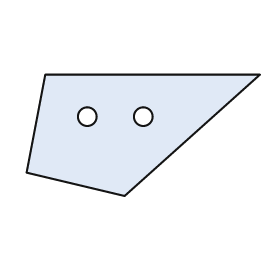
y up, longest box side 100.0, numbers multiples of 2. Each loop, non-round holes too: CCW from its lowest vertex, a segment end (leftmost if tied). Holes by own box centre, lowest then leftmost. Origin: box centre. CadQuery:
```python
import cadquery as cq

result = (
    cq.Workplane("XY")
    .moveTo(-8.0, -26.0)
    .lineTo(50.0, 26.0)
    .lineTo(-42.0, 26.0)
    .lineTo(-50.0, -16.0)
    .close()
    .moveTo(-24.0, 8.0)
    .circle(4.0)
    .moveTo(0.0, 8.0)
    .circle(4.0)
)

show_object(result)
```